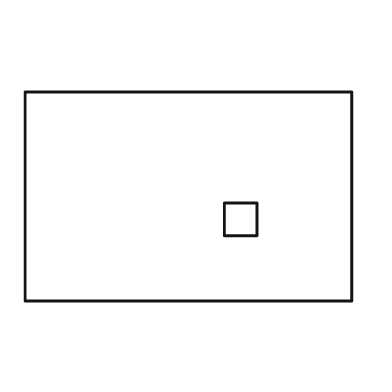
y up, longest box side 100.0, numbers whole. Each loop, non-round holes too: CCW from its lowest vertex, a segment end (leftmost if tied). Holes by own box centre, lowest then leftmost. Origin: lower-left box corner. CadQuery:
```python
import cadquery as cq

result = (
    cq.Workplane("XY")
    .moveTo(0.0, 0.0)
    .lineTo(100.0, 0.0)
    .lineTo(100.0, 64.0)
    .lineTo(0.0, 64.0)
    .close()
    .moveTo(61.0, 20.0)
    .lineTo(71.0, 20.0)
    .lineTo(71.0, 30.0)
    .lineTo(61.0, 30.0)
    .close()
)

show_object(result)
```